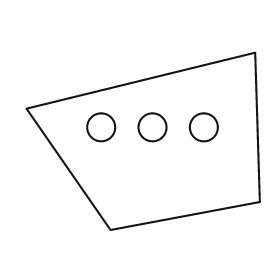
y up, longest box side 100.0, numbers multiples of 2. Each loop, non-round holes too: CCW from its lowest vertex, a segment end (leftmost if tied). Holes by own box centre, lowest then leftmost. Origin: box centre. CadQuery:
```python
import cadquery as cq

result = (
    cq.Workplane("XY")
    .moveTo(-14.0, -38.0)
    .lineTo(50.0, -26.0)
    .lineTo(48.0, 38.0)
    .lineTo(-50.0, 14.0)
    .close()
    .moveTo(-18.0, 6.0)
    .circle(6.0)
    .moveTo(4.0, 6.0)
    .circle(6.0)
    .moveTo(26.0, 6.0)
    .circle(6.0)
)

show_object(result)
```